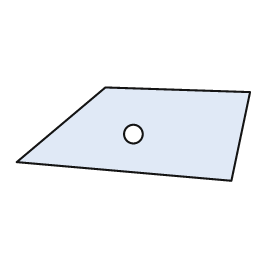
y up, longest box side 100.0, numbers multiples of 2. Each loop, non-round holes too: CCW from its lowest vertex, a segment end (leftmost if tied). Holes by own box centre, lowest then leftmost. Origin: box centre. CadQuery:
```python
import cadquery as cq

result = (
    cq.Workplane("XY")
    .moveTo(42.0, -20.0)
    .lineTo(50.0, 18.0)
    .lineTo(-12.0, 20.0)
    .lineTo(-50.0, -12.0)
    .close()
    .moveTo(0.0, 0.0)
    .circle(4.0)
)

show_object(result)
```